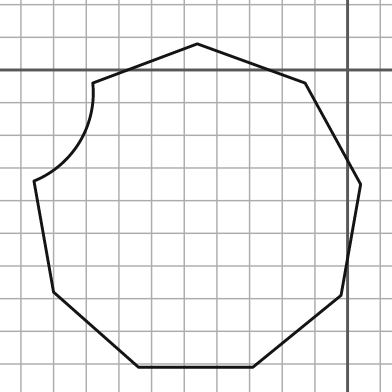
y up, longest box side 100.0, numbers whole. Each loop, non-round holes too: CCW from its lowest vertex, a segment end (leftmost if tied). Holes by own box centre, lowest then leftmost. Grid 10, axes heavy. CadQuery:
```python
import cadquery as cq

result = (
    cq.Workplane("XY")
    .moveTo(-64.0, -91.0)
    .lineTo(-29.0, -91.0)
    .lineTo(-2.0, -69.0)
    .lineTo(4.0, -35.0)
    .lineTo(-13.0, -4.0)
    .lineTo(-46.0, 8.0)
    .lineTo(-78.0, -4.0)
    .threePointArc((-82.0, -22.0), (-96.0, -34.0))
    .lineTo(-90.0, -68.0)
    .close()
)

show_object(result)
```